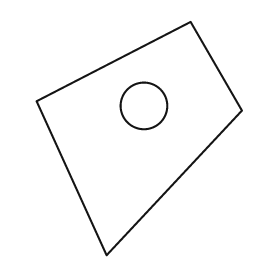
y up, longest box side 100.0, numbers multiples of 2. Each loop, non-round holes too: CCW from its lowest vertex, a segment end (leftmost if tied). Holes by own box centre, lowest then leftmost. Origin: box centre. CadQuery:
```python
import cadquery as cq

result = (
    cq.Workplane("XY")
    .moveTo(-14.0, -50.0)
    .lineTo(44.0, 12.0)
    .lineTo(22.0, 50.0)
    .lineTo(-44.0, 16.0)
    .close()
    .moveTo(2.0, 14.0)
    .circle(10.0)
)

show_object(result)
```